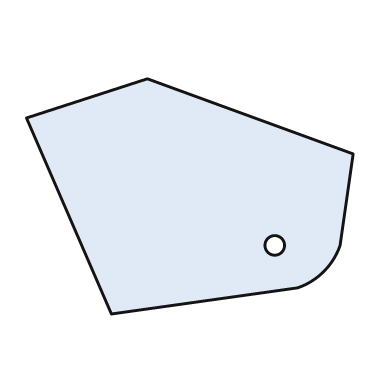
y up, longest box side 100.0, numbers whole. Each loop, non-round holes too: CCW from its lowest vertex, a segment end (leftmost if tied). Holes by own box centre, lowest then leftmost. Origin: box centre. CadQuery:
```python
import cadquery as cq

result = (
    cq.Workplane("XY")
    .moveTo(-24.0, -36.0)
    .lineTo(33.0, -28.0)
    .threePointArc((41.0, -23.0), (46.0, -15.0))
    .lineTo(50.0, 13.0)
    .lineTo(-13.0, 36.0)
    .lineTo(-50.0, 24.0)
    .close()
    .moveTo(26.0, -15.0)
    .circle(3.0)
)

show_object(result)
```